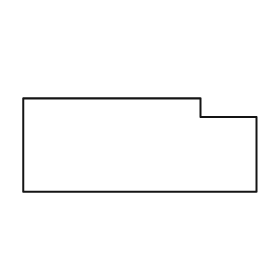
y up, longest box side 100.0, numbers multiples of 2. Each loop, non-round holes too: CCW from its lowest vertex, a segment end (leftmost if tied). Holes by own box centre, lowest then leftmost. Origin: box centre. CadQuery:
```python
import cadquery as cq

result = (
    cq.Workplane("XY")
    .moveTo(-50.0, -20.0)
    .lineTo(50.0, -20.0)
    .lineTo(50.0, 12.0)
    .lineTo(26.0, 12.0)
    .lineTo(26.0, 20.0)
    .lineTo(-50.0, 20.0)
    .close()
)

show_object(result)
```